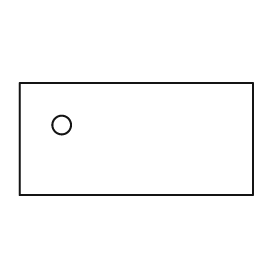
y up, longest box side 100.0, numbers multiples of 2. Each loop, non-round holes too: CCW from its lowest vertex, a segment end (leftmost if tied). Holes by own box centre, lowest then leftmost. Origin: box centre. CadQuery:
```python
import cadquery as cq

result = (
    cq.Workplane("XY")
    .moveTo(-50.0, -24.0)
    .lineTo(50.0, -24.0)
    .lineTo(50.0, 24.0)
    .lineTo(-50.0, 24.0)
    .close()
    .moveTo(-32.0, 6.0)
    .circle(4.0)
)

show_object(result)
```